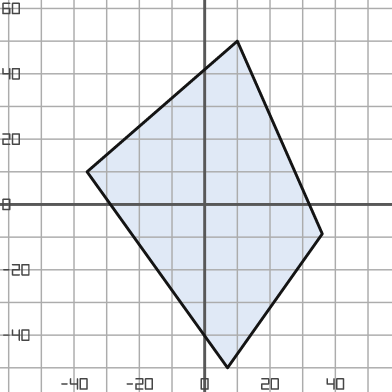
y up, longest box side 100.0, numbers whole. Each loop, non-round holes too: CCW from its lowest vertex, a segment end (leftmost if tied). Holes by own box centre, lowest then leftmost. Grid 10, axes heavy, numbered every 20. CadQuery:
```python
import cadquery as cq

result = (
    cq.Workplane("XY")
    .moveTo(7.0, -50.0)
    .lineTo(36.0, -9.0)
    .lineTo(10.0, 50.0)
    .lineTo(-36.0, 10.0)
    .close()
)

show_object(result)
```